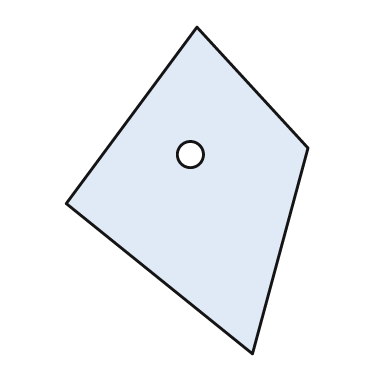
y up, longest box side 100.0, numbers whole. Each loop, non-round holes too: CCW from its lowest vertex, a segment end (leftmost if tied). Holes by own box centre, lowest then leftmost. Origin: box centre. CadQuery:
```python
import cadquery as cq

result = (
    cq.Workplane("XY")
    .moveTo(20.0, -50.0)
    .lineTo(37.0, 13.0)
    .lineTo(3.0, 50.0)
    .lineTo(-37.0, -4.0)
    .close()
    .moveTo(1.0, 11.0)
    .circle(4.0)
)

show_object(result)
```